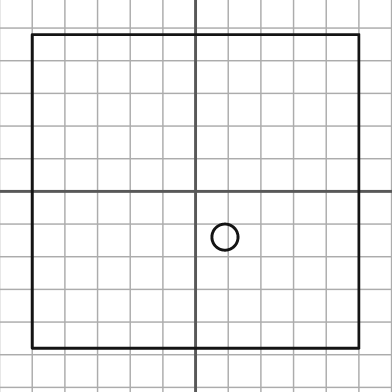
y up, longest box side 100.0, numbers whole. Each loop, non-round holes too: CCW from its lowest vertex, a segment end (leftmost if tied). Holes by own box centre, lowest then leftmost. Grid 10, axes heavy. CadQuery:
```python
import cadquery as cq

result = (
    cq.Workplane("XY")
    .moveTo(-50.0, -48.0)
    .lineTo(50.0, -48.0)
    .lineTo(50.0, 48.0)
    .lineTo(-50.0, 48.0)
    .close()
    .moveTo(9.0, -14.0)
    .circle(4.0)
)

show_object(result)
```